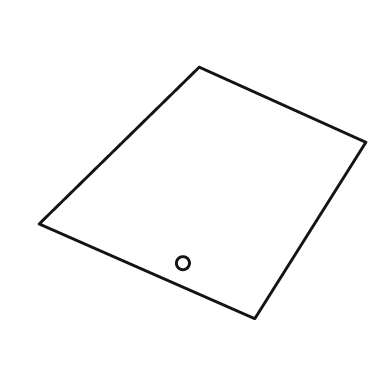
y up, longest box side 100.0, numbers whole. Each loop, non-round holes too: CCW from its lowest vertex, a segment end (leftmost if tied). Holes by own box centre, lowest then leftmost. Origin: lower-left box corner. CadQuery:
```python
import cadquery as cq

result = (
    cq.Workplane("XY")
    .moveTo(66.0, 0.0)
    .lineTo(100.0, 54.0)
    .lineTo(49.0, 77.0)
    .lineTo(0.0, 29.0)
    .close()
    .moveTo(44.0, 17.0)
    .circle(2.0)
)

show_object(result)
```